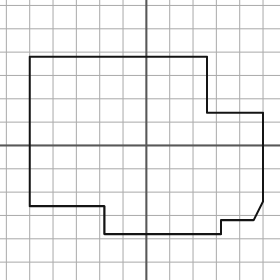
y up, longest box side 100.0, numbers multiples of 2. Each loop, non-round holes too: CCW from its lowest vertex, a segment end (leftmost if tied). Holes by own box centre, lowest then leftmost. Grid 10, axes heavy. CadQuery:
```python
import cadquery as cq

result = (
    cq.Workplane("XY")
    .moveTo(-18.0, -38.0)
    .lineTo(32.0, -38.0)
    .lineTo(32.0, -32.0)
    .lineTo(46.0, -32.0)
    .lineTo(50.0, -24.0)
    .lineTo(50.0, 14.0)
    .lineTo(26.0, 14.0)
    .lineTo(26.0, 38.0)
    .lineTo(-50.0, 38.0)
    .lineTo(-50.0, -26.0)
    .lineTo(-18.0, -26.0)
    .close()
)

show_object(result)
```